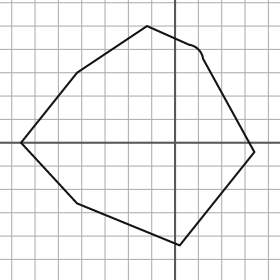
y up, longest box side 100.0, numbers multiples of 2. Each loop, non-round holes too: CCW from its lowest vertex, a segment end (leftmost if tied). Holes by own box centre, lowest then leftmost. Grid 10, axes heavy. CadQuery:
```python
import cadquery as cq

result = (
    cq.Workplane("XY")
    .moveTo(2.0, -44.0)
    .lineTo(34.0, -4.0)
    .lineTo(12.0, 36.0)
    .threePointArc((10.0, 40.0), (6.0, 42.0))
    .lineTo(-12.0, 50.0)
    .lineTo(-42.0, 30.0)
    .lineTo(-66.0, 0.0)
    .lineTo(-42.0, -26.0)
    .close()
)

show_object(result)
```